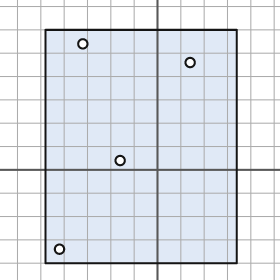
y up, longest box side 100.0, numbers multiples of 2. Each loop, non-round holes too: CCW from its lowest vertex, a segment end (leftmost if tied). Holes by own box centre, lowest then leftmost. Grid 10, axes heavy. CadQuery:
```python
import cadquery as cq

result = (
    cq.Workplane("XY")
    .moveTo(-48.0, -40.0)
    .lineTo(34.0, -40.0)
    .lineTo(34.0, 60.0)
    .lineTo(-48.0, 60.0)
    .close()
    .moveTo(-42.0, -34.0)
    .circle(2.0)
    .moveTo(-16.0, 4.0)
    .circle(2.0)
    .moveTo(14.0, 46.0)
    .circle(2.0)
    .moveTo(-32.0, 54.0)
    .circle(2.0)
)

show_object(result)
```